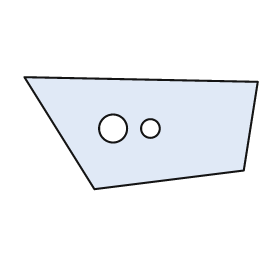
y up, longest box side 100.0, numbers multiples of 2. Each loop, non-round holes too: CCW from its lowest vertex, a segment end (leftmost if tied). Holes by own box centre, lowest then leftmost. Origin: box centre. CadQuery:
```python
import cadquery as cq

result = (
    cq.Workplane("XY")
    .moveTo(-20.0, -24.0)
    .lineTo(44.0, -16.0)
    .lineTo(50.0, 22.0)
    .lineTo(-50.0, 24.0)
    .close()
    .moveTo(-12.0, 2.0)
    .circle(6.0)
    .moveTo(4.0, 2.0)
    .circle(4.0)
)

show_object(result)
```